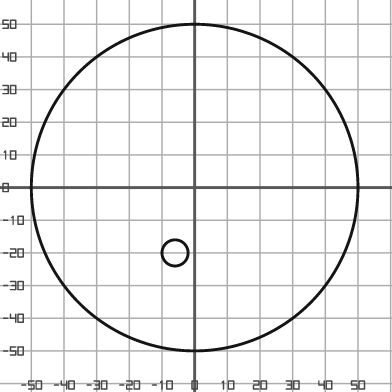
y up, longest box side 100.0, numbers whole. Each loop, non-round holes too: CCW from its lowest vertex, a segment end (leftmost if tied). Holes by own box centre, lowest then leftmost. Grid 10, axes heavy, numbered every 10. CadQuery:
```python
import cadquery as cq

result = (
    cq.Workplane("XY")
    .moveTo(0.0, 0.0)
    .circle(50.0)
    .moveTo(-6.0, -20.0)
    .circle(4.0)
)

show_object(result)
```